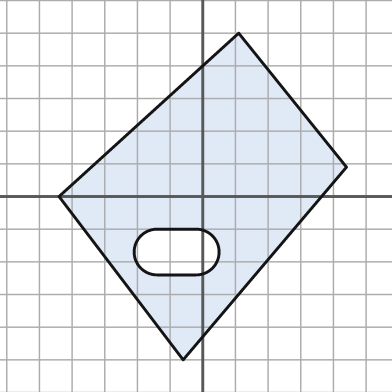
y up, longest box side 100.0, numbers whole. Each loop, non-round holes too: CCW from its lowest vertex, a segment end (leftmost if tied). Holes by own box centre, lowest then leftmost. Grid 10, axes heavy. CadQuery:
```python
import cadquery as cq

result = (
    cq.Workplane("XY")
    .moveTo(-6.0, -50.0)
    .lineTo(44.0, 9.0)
    .lineTo(11.0, 50.0)
    .lineTo(-44.0, 0.0)
    .close()
    .moveTo(-14.0, -24.0)
    .lineTo(-2.0, -24.0)
    .threePointArc((5.0, -17.0), (-2.0, -10.0))
    .lineTo(-14.0, -10.0)
    .threePointArc((-21.0, -17.0), (-14.0, -24.0))
    .close()
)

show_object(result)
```